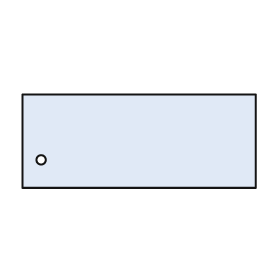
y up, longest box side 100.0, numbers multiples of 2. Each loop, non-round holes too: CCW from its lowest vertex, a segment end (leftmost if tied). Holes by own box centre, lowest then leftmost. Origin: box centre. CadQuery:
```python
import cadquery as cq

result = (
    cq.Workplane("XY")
    .moveTo(-50.0, -20.0)
    .lineTo(50.0, -20.0)
    .lineTo(50.0, 20.0)
    .lineTo(-50.0, 20.0)
    .close()
    .moveTo(-42.0, -8.0)
    .circle(2.0)
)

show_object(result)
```